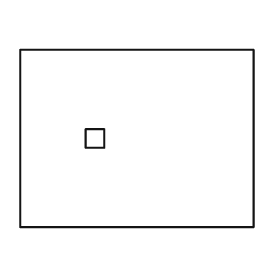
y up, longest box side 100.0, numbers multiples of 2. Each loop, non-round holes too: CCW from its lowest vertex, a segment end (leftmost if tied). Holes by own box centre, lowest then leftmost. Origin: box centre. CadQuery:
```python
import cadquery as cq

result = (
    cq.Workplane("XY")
    .moveTo(-50.0, -38.0)
    .lineTo(50.0, -38.0)
    .lineTo(50.0, 38.0)
    .lineTo(-50.0, 38.0)
    .close()
    .moveTo(-22.0, -4.0)
    .lineTo(-14.0, -4.0)
    .lineTo(-14.0, 4.0)
    .lineTo(-22.0, 4.0)
    .close()
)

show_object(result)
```